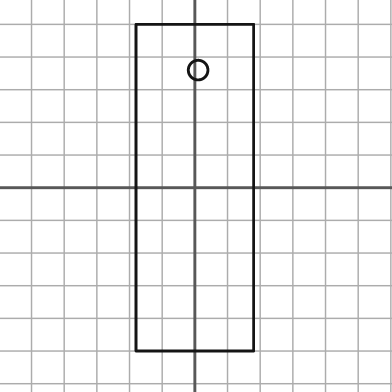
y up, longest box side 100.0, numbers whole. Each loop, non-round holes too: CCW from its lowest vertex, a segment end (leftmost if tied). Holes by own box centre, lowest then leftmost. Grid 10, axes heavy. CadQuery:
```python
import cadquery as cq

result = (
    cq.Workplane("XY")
    .moveTo(-18.0, -50.0)
    .lineTo(18.0, -50.0)
    .lineTo(18.0, 50.0)
    .lineTo(-18.0, 50.0)
    .close()
    .moveTo(1.0, 36.0)
    .circle(3.0)
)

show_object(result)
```